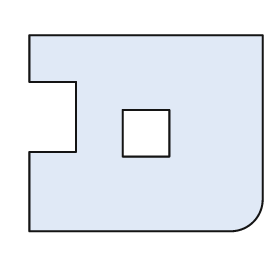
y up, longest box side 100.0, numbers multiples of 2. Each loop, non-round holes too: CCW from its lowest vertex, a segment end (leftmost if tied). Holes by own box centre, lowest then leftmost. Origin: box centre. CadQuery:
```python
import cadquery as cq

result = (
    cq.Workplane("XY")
    .moveTo(-50.0, -42.0)
    .lineTo(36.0, -42.0)
    .threePointArc((46.0, -38.0), (50.0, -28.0))
    .lineTo(50.0, 42.0)
    .lineTo(-50.0, 42.0)
    .lineTo(-50.0, 22.0)
    .lineTo(-30.0, 22.0)
    .lineTo(-30.0, -8.0)
    .lineTo(-50.0, -8.0)
    .close()
    .moveTo(-10.0, -10.0)
    .lineTo(10.0, -10.0)
    .lineTo(10.0, 10.0)
    .lineTo(-10.0, 10.0)
    .close()
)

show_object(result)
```